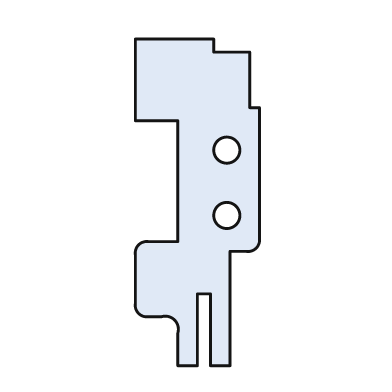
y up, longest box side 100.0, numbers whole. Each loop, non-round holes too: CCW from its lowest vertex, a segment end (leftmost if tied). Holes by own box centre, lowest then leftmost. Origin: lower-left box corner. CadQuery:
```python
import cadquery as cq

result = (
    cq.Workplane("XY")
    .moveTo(13.0, 0.0)
    .lineTo(19.0, 0.0)
    .lineTo(19.0, 22.0)
    .lineTo(23.0, 22.0)
    .lineTo(23.0, 0.0)
    .lineTo(29.0, 0.0)
    .lineTo(29.0, 35.0)
    .lineTo(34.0, 35.0)
    .threePointArc((37.0, 36.0), (38.0, 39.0))
    .lineTo(38.0, 79.0)
    .lineTo(35.0, 79.0)
    .lineTo(35.0, 96.0)
    .lineTo(24.0, 96.0)
    .lineTo(24.0, 100.0)
    .lineTo(0.0, 100.0)
    .lineTo(0.0, 75.0)
    .lineTo(13.0, 75.0)
    .lineTo(13.0, 38.0)
    .lineTo(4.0, 38.0)
    .threePointArc((1.0, 37.0), (0.0, 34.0))
    .lineTo(0.0, 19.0)
    .threePointArc((1.0, 16.0), (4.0, 15.0))
    .lineTo(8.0, 15.0)
    .threePointArc((12.0, 14.0), (13.0, 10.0))
    .close()
    .moveTo(28.0, 46.0)
    .circle(4.0)
    .moveTo(28.0, 66.0)
    .circle(4.0)
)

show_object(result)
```